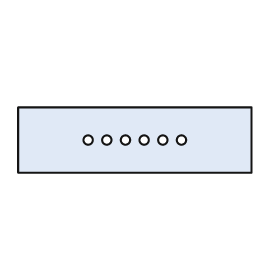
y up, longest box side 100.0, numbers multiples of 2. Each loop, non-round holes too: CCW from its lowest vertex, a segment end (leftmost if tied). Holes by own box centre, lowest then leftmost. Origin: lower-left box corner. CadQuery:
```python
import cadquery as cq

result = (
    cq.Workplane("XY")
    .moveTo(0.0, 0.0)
    .lineTo(100.0, 0.0)
    .lineTo(100.0, 28.0)
    .lineTo(0.0, 28.0)
    .close()
    .moveTo(30.0, 14.0)
    .circle(2.0)
    .moveTo(38.0, 14.0)
    .circle(2.0)
    .moveTo(46.0, 14.0)
    .circle(2.0)
    .moveTo(54.0, 14.0)
    .circle(2.0)
    .moveTo(62.0, 14.0)
    .circle(2.0)
    .moveTo(70.0, 14.0)
    .circle(2.0)
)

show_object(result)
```